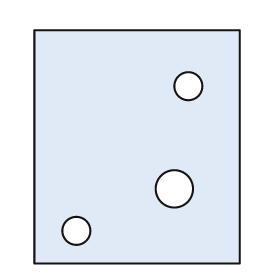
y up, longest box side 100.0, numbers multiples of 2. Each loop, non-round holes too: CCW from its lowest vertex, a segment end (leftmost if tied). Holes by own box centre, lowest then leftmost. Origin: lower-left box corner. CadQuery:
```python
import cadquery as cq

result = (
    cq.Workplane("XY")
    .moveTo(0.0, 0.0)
    .lineTo(88.0, 0.0)
    .lineTo(88.0, 100.0)
    .lineTo(0.0, 100.0)
    .close()
    .moveTo(18.0, 14.0)
    .circle(6.0)
    .moveTo(60.0, 32.0)
    .circle(8.0)
    .moveTo(66.0, 76.0)
    .circle(6.0)
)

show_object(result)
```